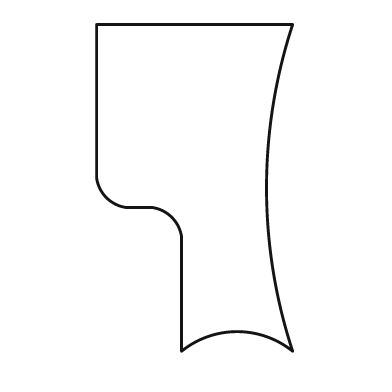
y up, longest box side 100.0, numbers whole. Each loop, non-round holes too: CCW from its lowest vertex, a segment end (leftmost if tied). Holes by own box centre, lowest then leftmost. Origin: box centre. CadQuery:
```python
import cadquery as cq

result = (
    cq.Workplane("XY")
    .moveTo(-4.0, -50.0)
    .threePointArc((13.0, -44.0), (30.0, -50.0))
    .threePointArc((22.0, 0.0), (30.0, 50.0))
    .lineTo(-30.0, 50.0)
    .lineTo(-30.0, 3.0)
    .threePointArc((-27.0, -3.0), (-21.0, -6.0))
    .lineTo(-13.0, -6.0)
    .threePointArc((-7.0, -9.0), (-4.0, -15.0))
    .close()
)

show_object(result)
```